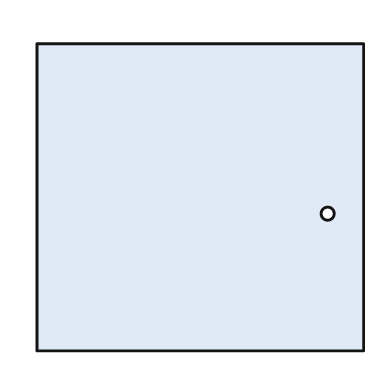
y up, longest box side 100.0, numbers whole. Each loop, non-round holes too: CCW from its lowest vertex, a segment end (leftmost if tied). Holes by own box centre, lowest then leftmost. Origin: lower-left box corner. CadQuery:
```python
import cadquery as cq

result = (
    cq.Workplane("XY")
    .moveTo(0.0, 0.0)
    .lineTo(100.0, 0.0)
    .lineTo(100.0, 94.0)
    .lineTo(0.0, 94.0)
    .close()
    .moveTo(89.0, 42.0)
    .circle(2.0)
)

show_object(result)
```